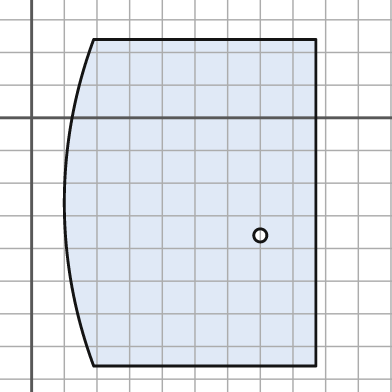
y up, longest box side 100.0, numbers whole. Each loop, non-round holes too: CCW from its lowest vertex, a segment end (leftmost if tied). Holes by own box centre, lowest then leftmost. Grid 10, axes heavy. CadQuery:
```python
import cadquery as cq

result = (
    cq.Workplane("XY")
    .moveTo(19.0, -76.0)
    .lineTo(87.0, -76.0)
    .lineTo(87.0, 24.0)
    .lineTo(19.0, 24.0)
    .threePointArc((10.0, -26.0), (19.0, -76.0))
    .close()
    .moveTo(70.0, -36.0)
    .circle(2.0)
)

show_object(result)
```